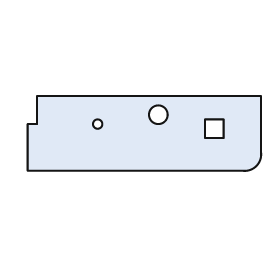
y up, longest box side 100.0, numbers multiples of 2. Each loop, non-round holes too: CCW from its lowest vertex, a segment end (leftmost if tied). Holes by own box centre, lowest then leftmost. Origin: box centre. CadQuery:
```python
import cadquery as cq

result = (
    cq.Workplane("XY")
    .moveTo(-50.0, -16.0)
    .lineTo(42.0, -16.0)
    .threePointArc((48.0, -14.0), (50.0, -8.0))
    .lineTo(50.0, 16.0)
    .lineTo(-46.0, 16.0)
    .lineTo(-46.0, 4.0)
    .lineTo(-50.0, 4.0)
    .close()
    .moveTo(26.0, -2.0)
    .lineTo(34.0, -2.0)
    .lineTo(34.0, 6.0)
    .lineTo(26.0, 6.0)
    .close()
    .moveTo(-20.0, 4.0)
    .circle(2.0)
    .moveTo(6.0, 8.0)
    .circle(4.0)
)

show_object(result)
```